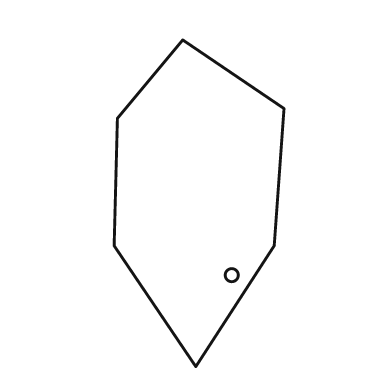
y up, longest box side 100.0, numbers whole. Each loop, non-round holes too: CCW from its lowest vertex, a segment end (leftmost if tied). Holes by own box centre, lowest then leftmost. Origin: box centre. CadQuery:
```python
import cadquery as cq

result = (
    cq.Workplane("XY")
    .moveTo(-1.0, -50.0)
    .lineTo(23.0, -13.0)
    .lineTo(26.0, 29.0)
    .lineTo(-5.0, 50.0)
    .lineTo(-25.0, 26.0)
    .lineTo(-26.0, -13.0)
    .close()
    .moveTo(10.0, -22.0)
    .circle(2.0)
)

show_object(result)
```